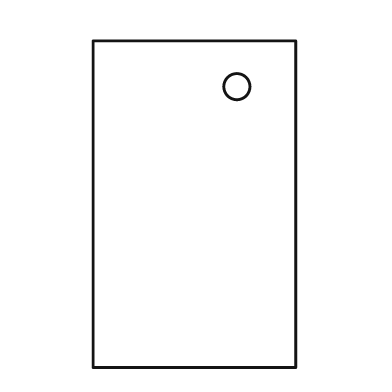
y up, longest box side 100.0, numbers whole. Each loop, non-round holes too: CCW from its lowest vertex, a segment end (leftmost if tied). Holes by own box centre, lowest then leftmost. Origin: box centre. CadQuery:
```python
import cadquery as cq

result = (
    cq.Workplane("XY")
    .moveTo(-31.0, -50.0)
    .lineTo(31.0, -50.0)
    .lineTo(31.0, 50.0)
    .lineTo(-31.0, 50.0)
    .close()
    .moveTo(13.0, 36.0)
    .circle(4.0)
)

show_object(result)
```